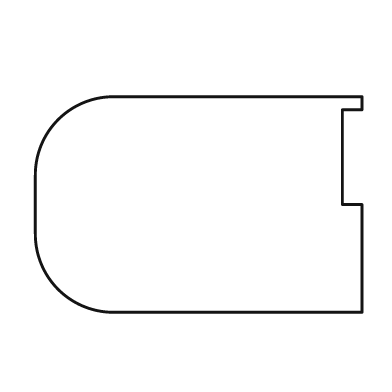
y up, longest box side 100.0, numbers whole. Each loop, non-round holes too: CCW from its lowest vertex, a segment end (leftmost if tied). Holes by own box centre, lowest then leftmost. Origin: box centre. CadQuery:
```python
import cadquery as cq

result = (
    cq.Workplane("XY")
    .moveTo(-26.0, -33.0)
    .lineTo(50.0, -33.0)
    .lineTo(50.0, 0.0)
    .lineTo(44.0, 0.0)
    .lineTo(44.0, 29.0)
    .lineTo(50.0, 29.0)
    .lineTo(50.0, 33.0)
    .lineTo(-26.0, 33.0)
    .threePointArc((-43.0, 26.0), (-50.0, 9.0))
    .lineTo(-50.0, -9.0)
    .threePointArc((-43.0, -26.0), (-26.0, -33.0))
    .close()
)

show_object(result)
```